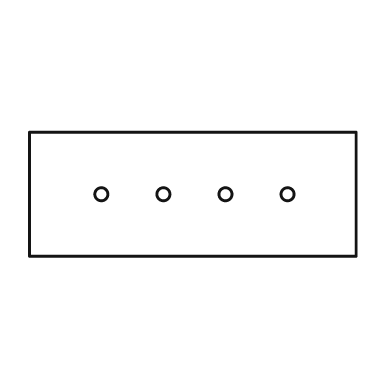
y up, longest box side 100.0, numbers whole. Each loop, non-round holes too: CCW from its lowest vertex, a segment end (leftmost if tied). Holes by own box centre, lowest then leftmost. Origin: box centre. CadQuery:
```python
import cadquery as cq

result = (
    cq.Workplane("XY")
    .moveTo(-50.0, -19.0)
    .lineTo(50.0, -19.0)
    .lineTo(50.0, 19.0)
    .lineTo(-50.0, 19.0)
    .close()
    .moveTo(-28.0, 0.0)
    .circle(2.0)
    .moveTo(-9.0, 0.0)
    .circle(2.0)
    .moveTo(10.0, 0.0)
    .circle(2.0)
    .moveTo(29.0, 0.0)
    .circle(2.0)
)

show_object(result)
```